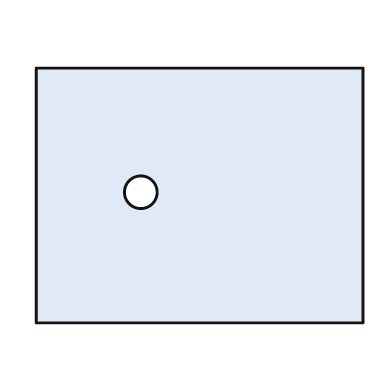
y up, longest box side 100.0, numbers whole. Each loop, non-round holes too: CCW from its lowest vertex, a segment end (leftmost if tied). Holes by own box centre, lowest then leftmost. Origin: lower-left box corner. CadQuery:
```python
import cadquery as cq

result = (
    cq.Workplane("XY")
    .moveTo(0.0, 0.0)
    .lineTo(100.0, 0.0)
    .lineTo(100.0, 78.0)
    .lineTo(0.0, 78.0)
    .close()
    .moveTo(32.0, 40.0)
    .circle(5.0)
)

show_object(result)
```